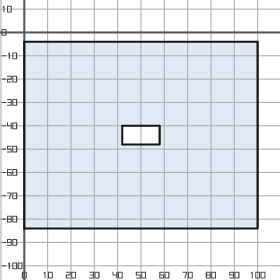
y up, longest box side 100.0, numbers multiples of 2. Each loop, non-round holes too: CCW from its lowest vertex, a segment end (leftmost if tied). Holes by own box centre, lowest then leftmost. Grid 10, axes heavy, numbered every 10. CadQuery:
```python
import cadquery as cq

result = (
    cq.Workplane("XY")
    .moveTo(0.0, -84.0)
    .lineTo(100.0, -84.0)
    .lineTo(100.0, -4.0)
    .lineTo(0.0, -4.0)
    .close()
    .moveTo(42.0, -48.0)
    .lineTo(58.0, -48.0)
    .lineTo(58.0, -40.0)
    .lineTo(42.0, -40.0)
    .close()
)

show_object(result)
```